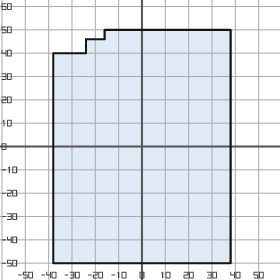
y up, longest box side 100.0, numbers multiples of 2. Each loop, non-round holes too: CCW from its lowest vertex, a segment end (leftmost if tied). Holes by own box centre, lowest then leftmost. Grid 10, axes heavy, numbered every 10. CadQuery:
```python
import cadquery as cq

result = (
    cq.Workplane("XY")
    .moveTo(-38.0, -50.0)
    .lineTo(38.0, -50.0)
    .lineTo(38.0, 50.0)
    .lineTo(-16.0, 50.0)
    .lineTo(-16.0, 46.0)
    .lineTo(-24.0, 46.0)
    .lineTo(-24.0, 40.0)
    .lineTo(-38.0, 40.0)
    .close()
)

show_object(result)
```